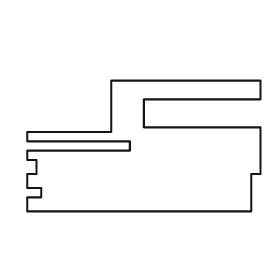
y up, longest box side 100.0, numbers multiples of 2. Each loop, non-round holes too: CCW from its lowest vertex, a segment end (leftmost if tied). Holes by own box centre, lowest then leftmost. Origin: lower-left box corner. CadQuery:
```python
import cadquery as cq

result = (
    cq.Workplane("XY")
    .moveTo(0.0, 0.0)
    .lineTo(96.0, 0.0)
    .lineTo(96.0, 16.0)
    .lineTo(100.0, 16.0)
    .lineTo(100.0, 36.0)
    .lineTo(50.0, 36.0)
    .lineTo(50.0, 48.0)
    .lineTo(100.0, 48.0)
    .lineTo(100.0, 56.0)
    .lineTo(36.0, 56.0)
    .lineTo(36.0, 34.0)
    .lineTo(0.0, 34.0)
    .lineTo(0.0, 30.0)
    .lineTo(44.0, 30.0)
    .lineTo(44.0, 26.0)
    .lineTo(0.0, 26.0)
    .lineTo(0.0, 22.0)
    .lineTo(4.0, 22.0)
    .lineTo(4.0, 16.0)
    .lineTo(0.0, 16.0)
    .lineTo(0.0, 10.0)
    .lineTo(6.0, 10.0)
    .lineTo(6.0, 6.0)
    .lineTo(0.0, 6.0)
    .close()
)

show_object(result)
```